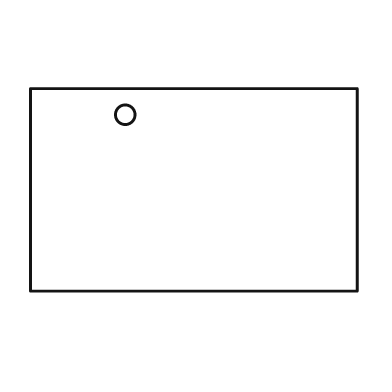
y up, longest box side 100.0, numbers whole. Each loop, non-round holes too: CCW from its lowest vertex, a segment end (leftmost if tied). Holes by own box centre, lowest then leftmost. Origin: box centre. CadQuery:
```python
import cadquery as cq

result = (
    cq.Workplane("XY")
    .moveTo(-50.0, -31.0)
    .lineTo(50.0, -31.0)
    .lineTo(50.0, 31.0)
    .lineTo(-50.0, 31.0)
    .close()
    .moveTo(-21.0, 23.0)
    .circle(3.0)
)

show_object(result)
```